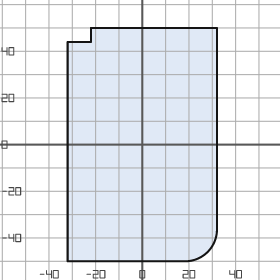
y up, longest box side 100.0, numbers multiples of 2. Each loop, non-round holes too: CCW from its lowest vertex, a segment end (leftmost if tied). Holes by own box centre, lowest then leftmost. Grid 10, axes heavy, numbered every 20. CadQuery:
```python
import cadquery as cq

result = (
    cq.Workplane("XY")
    .moveTo(-32.0, -50.0)
    .lineTo(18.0, -50.0)
    .threePointArc((28.0, -46.0), (32.0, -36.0))
    .lineTo(32.0, 50.0)
    .lineTo(-22.0, 50.0)
    .lineTo(-22.0, 44.0)
    .lineTo(-32.0, 44.0)
    .close()
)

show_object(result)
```